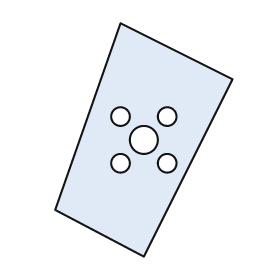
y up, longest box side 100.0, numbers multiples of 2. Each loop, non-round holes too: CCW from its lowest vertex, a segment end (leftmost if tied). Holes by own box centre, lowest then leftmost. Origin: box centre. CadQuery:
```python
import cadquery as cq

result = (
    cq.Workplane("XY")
    .moveTo(0.0, -50.0)
    .lineTo(38.0, 26.0)
    .lineTo(-10.0, 50.0)
    .lineTo(-38.0, -30.0)
    .close()
    .moveTo(-10.0, -10.0)
    .circle(4.0)
    .moveTo(10.0, -10.0)
    .circle(4.0)
    .moveTo(0.0, 0.0)
    .circle(6.0)
    .moveTo(-10.0, 10.0)
    .circle(4.0)
    .moveTo(10.0, 10.0)
    .circle(4.0)
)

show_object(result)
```